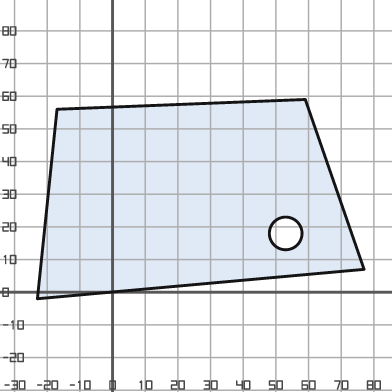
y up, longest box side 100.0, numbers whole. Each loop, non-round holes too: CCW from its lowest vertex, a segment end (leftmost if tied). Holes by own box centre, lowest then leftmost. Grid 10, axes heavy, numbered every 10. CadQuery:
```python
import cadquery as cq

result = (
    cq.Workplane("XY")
    .moveTo(-23.0, -2.0)
    .lineTo(77.0, 7.0)
    .lineTo(59.0, 59.0)
    .lineTo(-17.0, 56.0)
    .close()
    .moveTo(53.0, 18.0)
    .circle(5.0)
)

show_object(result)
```